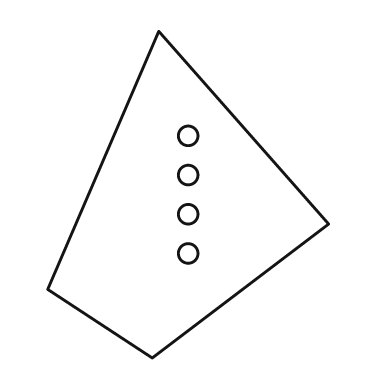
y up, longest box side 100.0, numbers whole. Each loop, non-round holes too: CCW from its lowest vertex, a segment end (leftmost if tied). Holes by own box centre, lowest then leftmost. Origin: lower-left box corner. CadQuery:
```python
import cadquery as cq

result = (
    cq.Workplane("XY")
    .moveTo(32.0, 0.0)
    .lineTo(86.0, 41.0)
    .lineTo(34.0, 100.0)
    .lineTo(0.0, 21.0)
    .close()
    .moveTo(43.0, 32.0)
    .circle(3.0)
    .moveTo(43.0, 44.0)
    .circle(3.0)
    .moveTo(43.0, 56.0)
    .circle(3.0)
    .moveTo(43.0, 68.0)
    .circle(3.0)
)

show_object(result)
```